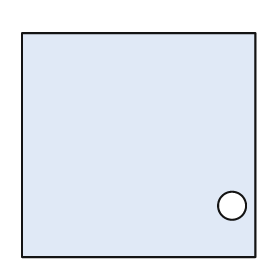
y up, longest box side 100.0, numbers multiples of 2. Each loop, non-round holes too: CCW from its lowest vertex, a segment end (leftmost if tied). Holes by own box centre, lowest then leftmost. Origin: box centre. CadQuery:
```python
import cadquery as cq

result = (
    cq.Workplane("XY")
    .moveTo(-50.0, -48.0)
    .lineTo(50.0, -48.0)
    .lineTo(50.0, 48.0)
    .lineTo(-50.0, 48.0)
    .close()
    .moveTo(40.0, -26.0)
    .circle(6.0)
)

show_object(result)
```